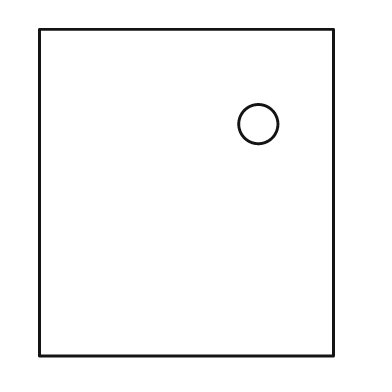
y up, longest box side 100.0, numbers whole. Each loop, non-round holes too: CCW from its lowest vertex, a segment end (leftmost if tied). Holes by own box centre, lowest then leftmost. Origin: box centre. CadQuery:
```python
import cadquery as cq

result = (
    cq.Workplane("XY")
    .moveTo(-45.0, -50.0)
    .lineTo(45.0, -50.0)
    .lineTo(45.0, 50.0)
    .lineTo(-45.0, 50.0)
    .close()
    .moveTo(22.0, 21.0)
    .circle(6.0)
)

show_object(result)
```